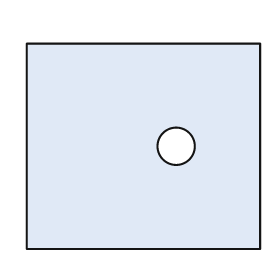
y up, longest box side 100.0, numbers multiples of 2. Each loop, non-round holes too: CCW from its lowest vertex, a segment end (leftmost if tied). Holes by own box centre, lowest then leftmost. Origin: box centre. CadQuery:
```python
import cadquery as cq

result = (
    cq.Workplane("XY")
    .moveTo(-50.0, -44.0)
    .lineTo(50.0, -44.0)
    .lineTo(50.0, 44.0)
    .lineTo(-50.0, 44.0)
    .close()
    .moveTo(14.0, 0.0)
    .circle(8.0)
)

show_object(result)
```